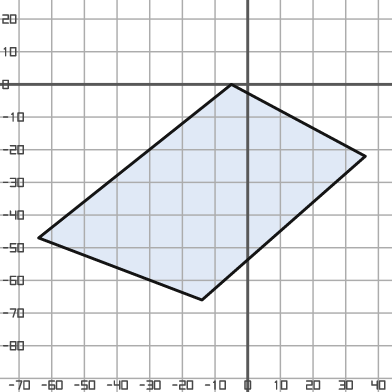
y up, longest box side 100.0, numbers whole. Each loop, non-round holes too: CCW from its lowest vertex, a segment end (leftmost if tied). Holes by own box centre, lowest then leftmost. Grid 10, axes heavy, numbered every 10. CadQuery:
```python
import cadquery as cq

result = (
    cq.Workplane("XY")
    .moveTo(-14.0, -66.0)
    .lineTo(36.0, -22.0)
    .lineTo(-5.0, 0.0)
    .lineTo(-64.0, -47.0)
    .close()
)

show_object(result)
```